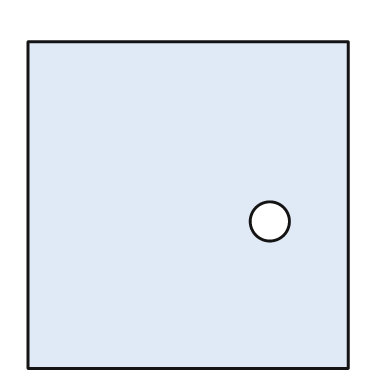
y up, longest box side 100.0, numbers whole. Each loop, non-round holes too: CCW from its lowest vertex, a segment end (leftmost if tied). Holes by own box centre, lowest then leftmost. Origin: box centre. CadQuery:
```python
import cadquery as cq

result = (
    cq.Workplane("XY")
    .moveTo(-49.0, -50.0)
    .lineTo(49.0, -50.0)
    .lineTo(49.0, 50.0)
    .lineTo(-49.0, 50.0)
    .close()
    .moveTo(25.0, -5.0)
    .circle(6.0)
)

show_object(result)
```